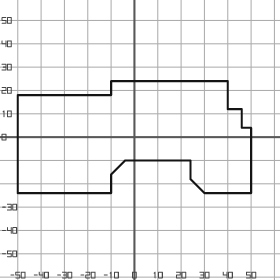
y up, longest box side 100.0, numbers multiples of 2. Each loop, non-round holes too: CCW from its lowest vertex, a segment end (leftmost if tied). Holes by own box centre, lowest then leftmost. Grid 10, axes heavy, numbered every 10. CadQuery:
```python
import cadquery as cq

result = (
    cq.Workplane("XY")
    .moveTo(-50.0, -24.0)
    .lineTo(-10.0, -24.0)
    .lineTo(-10.0, -16.0)
    .lineTo(-4.0, -10.0)
    .lineTo(24.0, -10.0)
    .lineTo(24.0, -18.0)
    .lineTo(30.0, -24.0)
    .lineTo(50.0, -24.0)
    .lineTo(50.0, 4.0)
    .lineTo(46.0, 4.0)
    .lineTo(46.0, 12.0)
    .lineTo(40.0, 12.0)
    .lineTo(40.0, 24.0)
    .lineTo(-10.0, 24.0)
    .lineTo(-10.0, 18.0)
    .lineTo(-50.0, 18.0)
    .close()
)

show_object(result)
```